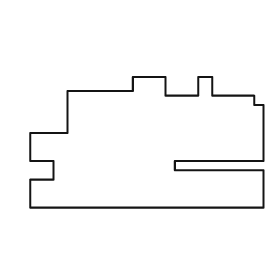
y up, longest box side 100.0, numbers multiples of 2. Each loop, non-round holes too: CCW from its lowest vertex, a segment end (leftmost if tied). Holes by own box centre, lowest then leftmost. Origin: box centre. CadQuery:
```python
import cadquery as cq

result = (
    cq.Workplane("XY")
    .moveTo(-50.0, -28.0)
    .lineTo(50.0, -28.0)
    .lineTo(50.0, -12.0)
    .lineTo(12.0, -12.0)
    .lineTo(12.0, -8.0)
    .lineTo(50.0, -8.0)
    .lineTo(50.0, 16.0)
    .lineTo(46.0, 16.0)
    .lineTo(46.0, 20.0)
    .lineTo(28.0, 20.0)
    .lineTo(28.0, 28.0)
    .lineTo(22.0, 28.0)
    .lineTo(22.0, 20.0)
    .lineTo(8.0, 20.0)
    .lineTo(8.0, 28.0)
    .lineTo(-6.0, 28.0)
    .lineTo(-6.0, 22.0)
    .lineTo(-34.0, 22.0)
    .lineTo(-34.0, 4.0)
    .lineTo(-50.0, 4.0)
    .lineTo(-50.0, -8.0)
    .lineTo(-40.0, -8.0)
    .lineTo(-40.0, -16.0)
    .lineTo(-50.0, -16.0)
    .close()
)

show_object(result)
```